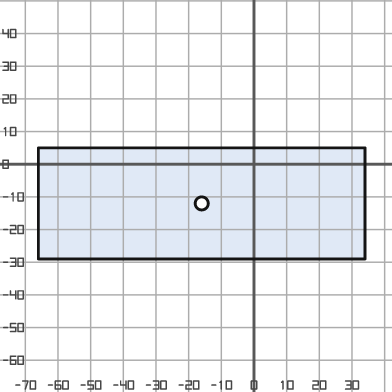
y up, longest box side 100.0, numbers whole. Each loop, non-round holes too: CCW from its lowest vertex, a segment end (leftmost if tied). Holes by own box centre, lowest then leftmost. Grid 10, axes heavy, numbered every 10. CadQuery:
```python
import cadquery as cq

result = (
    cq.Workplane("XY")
    .moveTo(-66.0, -29.0)
    .lineTo(34.0, -29.0)
    .lineTo(34.0, 5.0)
    .lineTo(-66.0, 5.0)
    .close()
    .moveTo(-16.0, -12.0)
    .circle(2.0)
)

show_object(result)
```